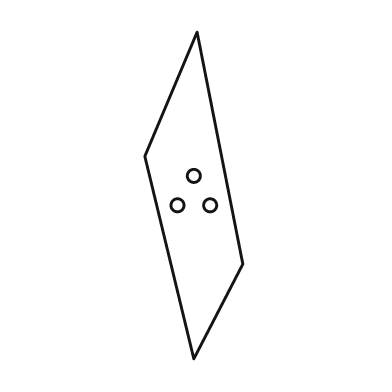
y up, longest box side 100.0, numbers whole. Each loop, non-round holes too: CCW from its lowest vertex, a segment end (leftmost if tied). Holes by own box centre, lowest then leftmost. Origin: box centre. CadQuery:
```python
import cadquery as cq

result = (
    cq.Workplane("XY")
    .moveTo(0.0, -50.0)
    .lineTo(15.0, -21.0)
    .lineTo(1.0, 50.0)
    .lineTo(-15.0, 12.0)
    .close()
    .moveTo(-5.0, -3.0)
    .circle(2.0)
    .moveTo(5.0, -3.0)
    .circle(2.0)
    .moveTo(0.0, 6.0)
    .circle(2.0)
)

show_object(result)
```